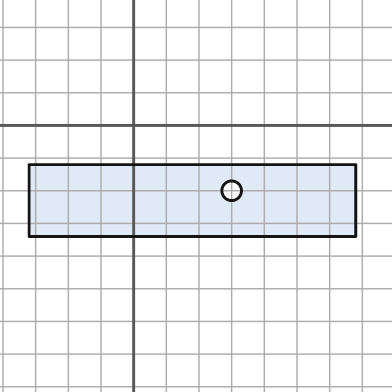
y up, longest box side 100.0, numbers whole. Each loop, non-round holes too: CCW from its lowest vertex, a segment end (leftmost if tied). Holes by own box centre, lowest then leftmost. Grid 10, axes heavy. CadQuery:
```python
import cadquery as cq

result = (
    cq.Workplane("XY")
    .moveTo(-32.0, -34.0)
    .lineTo(68.0, -34.0)
    .lineTo(68.0, -12.0)
    .lineTo(-32.0, -12.0)
    .close()
    .moveTo(30.0, -20.0)
    .circle(3.0)
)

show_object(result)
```